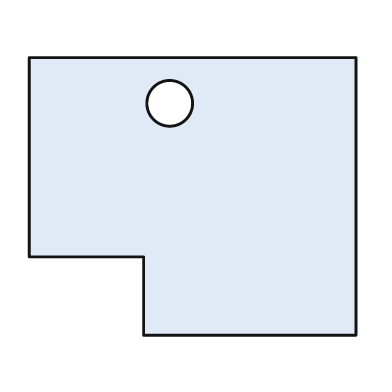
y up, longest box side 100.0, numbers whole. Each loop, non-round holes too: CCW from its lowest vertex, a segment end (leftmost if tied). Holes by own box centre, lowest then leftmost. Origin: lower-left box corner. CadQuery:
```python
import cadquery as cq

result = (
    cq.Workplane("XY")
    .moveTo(35.0, 0.0)
    .lineTo(100.0, 0.0)
    .lineTo(100.0, 85.0)
    .lineTo(0.0, 85.0)
    .lineTo(0.0, 24.0)
    .lineTo(35.0, 24.0)
    .close()
    .moveTo(43.0, 71.0)
    .circle(7.0)
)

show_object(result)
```